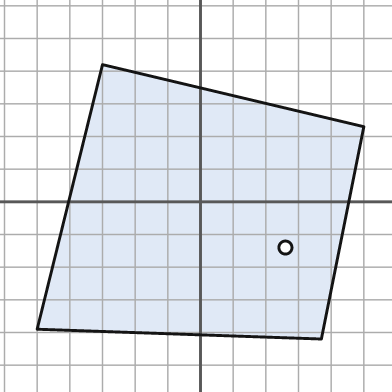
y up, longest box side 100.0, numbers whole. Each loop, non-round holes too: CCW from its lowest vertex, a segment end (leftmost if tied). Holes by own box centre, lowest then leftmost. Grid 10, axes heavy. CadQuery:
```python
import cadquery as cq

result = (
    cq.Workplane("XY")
    .moveTo(37.0, -42.0)
    .lineTo(50.0, 23.0)
    .lineTo(-30.0, 42.0)
    .lineTo(-50.0, -39.0)
    .close()
    .moveTo(26.0, -14.0)
    .circle(2.0)
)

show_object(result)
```